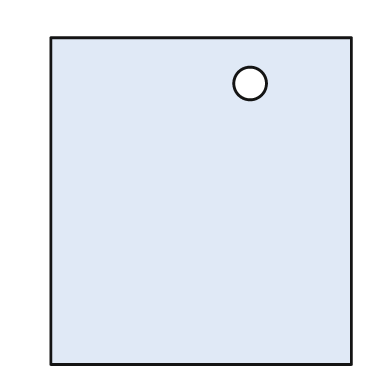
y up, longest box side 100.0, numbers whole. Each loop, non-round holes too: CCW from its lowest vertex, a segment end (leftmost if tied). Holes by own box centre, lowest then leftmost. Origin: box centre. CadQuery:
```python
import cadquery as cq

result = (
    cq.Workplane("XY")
    .moveTo(-46.0, -50.0)
    .lineTo(46.0, -50.0)
    .lineTo(46.0, 50.0)
    .lineTo(-46.0, 50.0)
    .close()
    .moveTo(15.0, 36.0)
    .circle(5.0)
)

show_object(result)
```